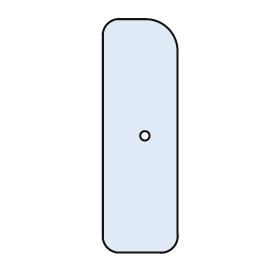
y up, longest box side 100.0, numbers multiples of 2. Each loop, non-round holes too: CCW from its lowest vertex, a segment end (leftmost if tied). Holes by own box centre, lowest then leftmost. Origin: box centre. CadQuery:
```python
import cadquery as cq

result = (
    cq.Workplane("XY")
    .moveTo(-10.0, -50.0)
    .lineTo(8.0, -50.0)
    .threePointArc((14.0, -48.0), (16.0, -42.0))
    .lineTo(16.0, 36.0)
    .threePointArc((12.0, 46.0), (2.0, 50.0))
    .lineTo(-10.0, 50.0)
    .threePointArc((-14.0, 48.0), (-16.0, 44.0))
    .lineTo(-16.0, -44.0)
    .threePointArc((-14.0, -48.0), (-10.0, -50.0))
    .close()
    .moveTo(2.0, 0.0)
    .circle(2.0)
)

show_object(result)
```